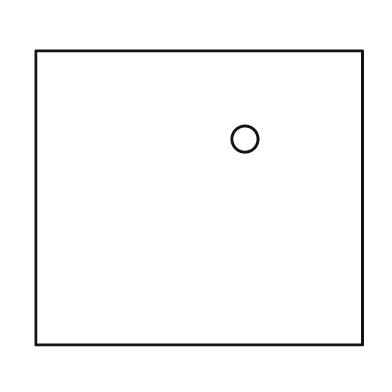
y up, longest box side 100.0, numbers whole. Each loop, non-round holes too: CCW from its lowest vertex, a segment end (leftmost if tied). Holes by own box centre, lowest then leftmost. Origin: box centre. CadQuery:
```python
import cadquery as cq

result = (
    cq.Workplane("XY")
    .moveTo(-50.0, -45.0)
    .lineTo(50.0, -45.0)
    .lineTo(50.0, 45.0)
    .lineTo(-50.0, 45.0)
    .close()
    .moveTo(14.0, 18.0)
    .circle(4.0)
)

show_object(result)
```